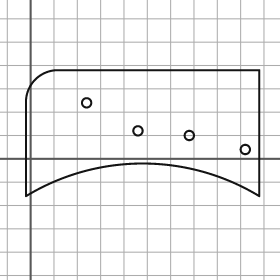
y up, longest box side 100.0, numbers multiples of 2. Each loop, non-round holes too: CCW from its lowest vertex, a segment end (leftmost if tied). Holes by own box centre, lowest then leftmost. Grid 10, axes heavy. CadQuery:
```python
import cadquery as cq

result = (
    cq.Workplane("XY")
    .moveTo(-2.0, -16.0)
    .threePointArc((48.0, -2.0), (98.0, -16.0))
    .lineTo(98.0, 38.0)
    .lineTo(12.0, 38.0)
    .threePointArc((2.0, 34.0), (-2.0, 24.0))
    .close()
    .moveTo(92.0, 4.0)
    .circle(2.0)
    .moveTo(68.0, 10.0)
    .circle(2.0)
    .moveTo(46.0, 12.0)
    .circle(2.0)
    .moveTo(24.0, 24.0)
    .circle(2.0)
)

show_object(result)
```